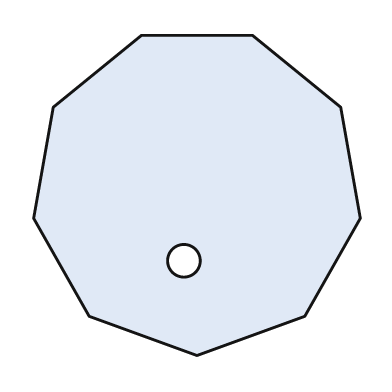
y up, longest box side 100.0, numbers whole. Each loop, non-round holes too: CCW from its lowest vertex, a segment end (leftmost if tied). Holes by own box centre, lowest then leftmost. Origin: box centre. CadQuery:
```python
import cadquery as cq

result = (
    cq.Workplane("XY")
    .moveTo(0.0, -49.0)
    .lineTo(33.0, -37.0)
    .lineTo(50.0, -7.0)
    .lineTo(44.0, 27.0)
    .lineTo(17.0, 49.0)
    .lineTo(-17.0, 49.0)
    .lineTo(-44.0, 27.0)
    .lineTo(-50.0, -7.0)
    .lineTo(-33.0, -37.0)
    .close()
    .moveTo(-4.0, -20.0)
    .circle(5.0)
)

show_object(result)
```